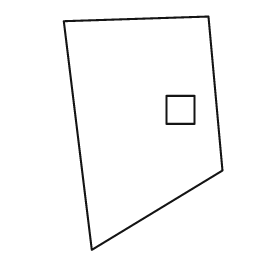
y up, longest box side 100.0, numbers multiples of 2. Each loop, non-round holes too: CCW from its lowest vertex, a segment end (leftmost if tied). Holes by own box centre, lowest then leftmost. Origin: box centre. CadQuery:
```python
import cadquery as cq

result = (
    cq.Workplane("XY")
    .moveTo(-22.0, -50.0)
    .lineTo(34.0, -16.0)
    .lineTo(28.0, 50.0)
    .lineTo(-34.0, 48.0)
    .close()
    .moveTo(10.0, 4.0)
    .lineTo(22.0, 4.0)
    .lineTo(22.0, 16.0)
    .lineTo(10.0, 16.0)
    .close()
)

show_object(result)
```